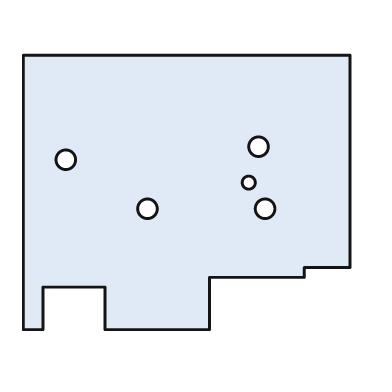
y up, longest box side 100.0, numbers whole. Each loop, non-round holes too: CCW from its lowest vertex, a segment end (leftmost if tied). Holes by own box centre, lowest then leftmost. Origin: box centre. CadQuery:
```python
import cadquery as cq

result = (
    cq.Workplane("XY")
    .moveTo(-50.0, -42.0)
    .lineTo(-44.0, -42.0)
    .lineTo(-44.0, -29.0)
    .lineTo(-25.0, -29.0)
    .lineTo(-25.0, -42.0)
    .lineTo(7.0, -42.0)
    .lineTo(7.0, -26.0)
    .lineTo(36.0, -26.0)
    .lineTo(36.0, -23.0)
    .lineTo(50.0, -23.0)
    .lineTo(50.0, 42.0)
    .lineTo(-50.0, 42.0)
    .close()
    .moveTo(-12.0, -5.0)
    .circle(3.0)
    .moveTo(24.0, -5.0)
    .circle(3.0)
    .moveTo(19.0, 3.0)
    .circle(2.0)
    .moveTo(-37.0, 10.0)
    .circle(3.0)
    .moveTo(22.0, 14.0)
    .circle(3.0)
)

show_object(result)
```